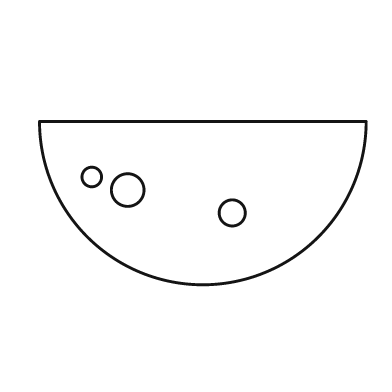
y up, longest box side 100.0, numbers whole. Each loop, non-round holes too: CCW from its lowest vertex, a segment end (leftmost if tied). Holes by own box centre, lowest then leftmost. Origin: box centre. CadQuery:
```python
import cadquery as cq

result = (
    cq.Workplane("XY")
    .moveTo(-50.0, 25.0)
    .threePointArc((0.0, -25.0), (50.0, 25.0))
    .close()
    .moveTo(9.0, -3.0)
    .circle(4.0)
    .moveTo(-23.0, 4.0)
    .circle(5.0)
    .moveTo(-34.0, 8.0)
    .circle(3.0)
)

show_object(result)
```